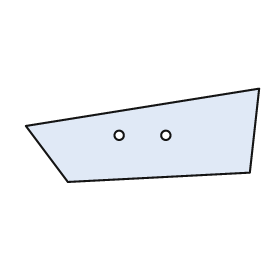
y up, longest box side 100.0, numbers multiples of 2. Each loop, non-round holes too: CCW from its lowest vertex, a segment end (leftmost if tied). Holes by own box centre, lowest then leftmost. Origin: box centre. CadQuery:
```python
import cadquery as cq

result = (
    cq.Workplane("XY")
    .moveTo(-32.0, -20.0)
    .lineTo(46.0, -16.0)
    .lineTo(50.0, 20.0)
    .lineTo(-50.0, 4.0)
    .close()
    .moveTo(-10.0, 0.0)
    .circle(2.0)
    .moveTo(10.0, 0.0)
    .circle(2.0)
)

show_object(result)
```